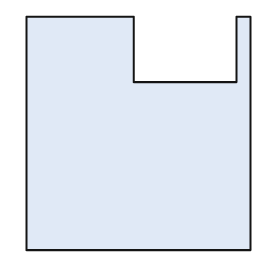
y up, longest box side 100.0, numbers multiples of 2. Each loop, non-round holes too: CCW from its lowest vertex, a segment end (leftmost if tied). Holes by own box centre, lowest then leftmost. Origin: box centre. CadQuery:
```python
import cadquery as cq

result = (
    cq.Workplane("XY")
    .moveTo(-48.0, -50.0)
    .lineTo(48.0, -50.0)
    .lineTo(48.0, 50.0)
    .lineTo(42.0, 50.0)
    .lineTo(42.0, 22.0)
    .lineTo(-2.0, 22.0)
    .lineTo(-2.0, 50.0)
    .lineTo(-48.0, 50.0)
    .close()
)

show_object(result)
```